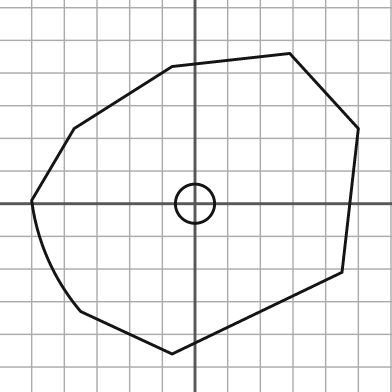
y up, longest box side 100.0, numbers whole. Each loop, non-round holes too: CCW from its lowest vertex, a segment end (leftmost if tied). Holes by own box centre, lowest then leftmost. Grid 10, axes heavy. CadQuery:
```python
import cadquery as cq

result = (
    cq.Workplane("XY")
    .moveTo(-7.0, -46.0)
    .lineTo(45.0, -21.0)
    .lineTo(50.0, 23.0)
    .lineTo(29.0, 46.0)
    .lineTo(-7.0, 42.0)
    .lineTo(-37.0, 23.0)
    .lineTo(-50.0, 1.0)
    .threePointArc((-45.0, -17.0), (-35.0, -33.0))
    .close()
    .moveTo(0.0, 0.0)
    .circle(6.0)
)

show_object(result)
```